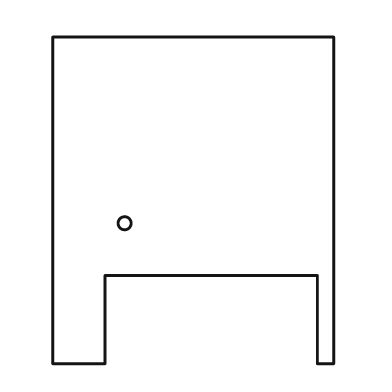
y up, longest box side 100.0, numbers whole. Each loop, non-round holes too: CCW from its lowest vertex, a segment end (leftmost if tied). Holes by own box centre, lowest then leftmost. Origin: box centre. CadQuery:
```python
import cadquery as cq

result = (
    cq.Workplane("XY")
    .moveTo(-43.0, -50.0)
    .lineTo(-27.0, -50.0)
    .lineTo(-27.0, -23.0)
    .lineTo(38.0, -23.0)
    .lineTo(38.0, -50.0)
    .lineTo(43.0, -50.0)
    .lineTo(43.0, 50.0)
    .lineTo(-43.0, 50.0)
    .close()
    .moveTo(-21.0, -7.0)
    .circle(2.0)
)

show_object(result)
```